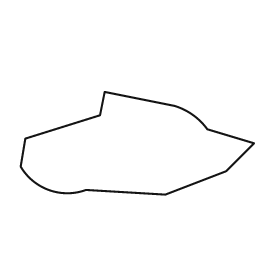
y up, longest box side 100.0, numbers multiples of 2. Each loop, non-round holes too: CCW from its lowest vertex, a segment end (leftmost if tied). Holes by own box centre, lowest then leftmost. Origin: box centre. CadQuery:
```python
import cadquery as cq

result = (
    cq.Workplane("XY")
    .moveTo(12.0, -22.0)
    .lineTo(38.0, -12.0)
    .lineTo(50.0, 0.0)
    .lineTo(30.0, 6.0)
    .threePointArc((24.0, 12.0), (16.0, 16.0))
    .lineTo(-14.0, 22.0)
    .lineTo(-16.0, 12.0)
    .lineTo(-48.0, 2.0)
    .lineTo(-50.0, -10.0)
    .threePointArc((-38.0, -20.0), (-22.0, -20.0))
    .close()
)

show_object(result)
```